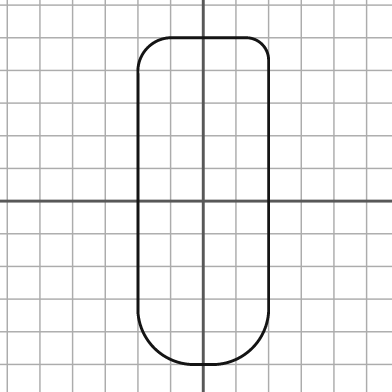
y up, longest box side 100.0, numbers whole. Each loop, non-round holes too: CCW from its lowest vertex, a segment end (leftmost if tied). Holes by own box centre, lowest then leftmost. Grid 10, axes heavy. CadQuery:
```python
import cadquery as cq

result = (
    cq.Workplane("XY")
    .moveTo(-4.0, -50.0)
    .lineTo(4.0, -50.0)
    .threePointArc((15.0, -45.0), (20.0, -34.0))
    .lineTo(20.0, 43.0)
    .threePointArc((18.0, 48.0), (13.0, 50.0))
    .lineTo(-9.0, 50.0)
    .threePointArc((-17.0, 47.0), (-20.0, 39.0))
    .lineTo(-20.0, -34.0)
    .threePointArc((-15.0, -45.0), (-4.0, -50.0))
    .close()
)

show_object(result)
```